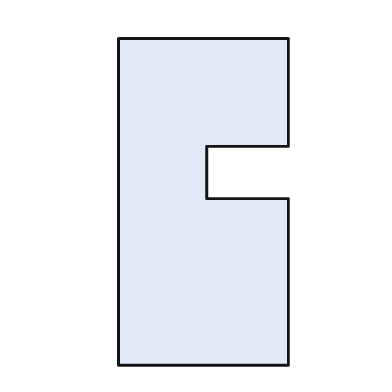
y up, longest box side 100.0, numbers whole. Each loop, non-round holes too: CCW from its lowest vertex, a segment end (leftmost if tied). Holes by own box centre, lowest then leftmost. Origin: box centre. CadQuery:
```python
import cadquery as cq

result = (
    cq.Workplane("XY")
    .moveTo(-26.0, -50.0)
    .lineTo(26.0, -50.0)
    .lineTo(26.0, 1.0)
    .lineTo(1.0, 1.0)
    .lineTo(1.0, 17.0)
    .lineTo(26.0, 17.0)
    .lineTo(26.0, 50.0)
    .lineTo(-26.0, 50.0)
    .close()
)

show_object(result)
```